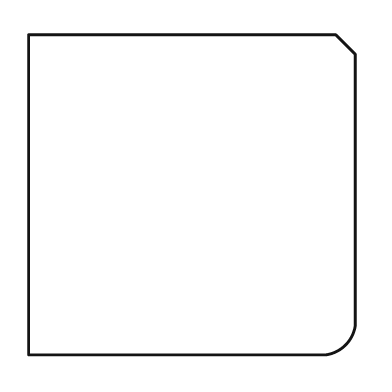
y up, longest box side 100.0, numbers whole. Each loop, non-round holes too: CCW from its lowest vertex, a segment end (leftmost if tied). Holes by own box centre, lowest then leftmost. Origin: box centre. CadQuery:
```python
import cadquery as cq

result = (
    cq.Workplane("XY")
    .moveTo(-50.0, -49.0)
    .lineTo(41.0, -49.0)
    .threePointArc((47.0, -46.0), (50.0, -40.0))
    .lineTo(50.0, 43.0)
    .lineTo(44.0, 49.0)
    .lineTo(-50.0, 49.0)
    .close()
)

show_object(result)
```